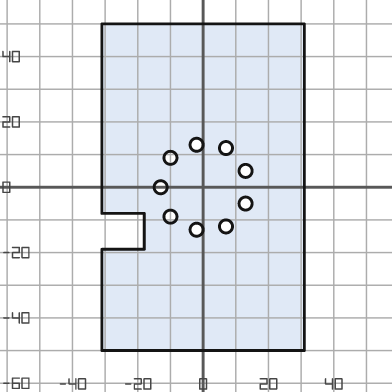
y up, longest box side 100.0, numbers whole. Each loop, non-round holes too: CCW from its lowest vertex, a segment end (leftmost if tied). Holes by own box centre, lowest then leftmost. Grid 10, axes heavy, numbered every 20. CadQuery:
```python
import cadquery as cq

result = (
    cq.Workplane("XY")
    .moveTo(-31.0, -50.0)
    .lineTo(31.0, -50.0)
    .lineTo(31.0, 50.0)
    .lineTo(-31.0, 50.0)
    .lineTo(-31.0, -8.0)
    .lineTo(-18.0, -8.0)
    .lineTo(-18.0, -19.0)
    .lineTo(-31.0, -19.0)
    .close()
    .moveTo(-2.0, -13.0)
    .circle(2.0)
    .moveTo(7.0, -12.0)
    .circle(2.0)
    .moveTo(-10.0, -9.0)
    .circle(2.0)
    .moveTo(13.0, -5.0)
    .circle(2.0)
    .moveTo(-13.0, 0.0)
    .circle(2.0)
    .moveTo(13.0, 5.0)
    .circle(2.0)
    .moveTo(-10.0, 9.0)
    .circle(2.0)
    .moveTo(7.0, 12.0)
    .circle(2.0)
    .moveTo(-2.0, 13.0)
    .circle(2.0)
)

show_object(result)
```